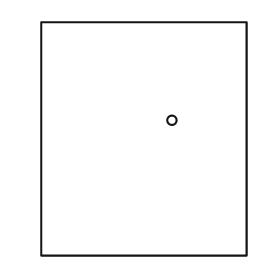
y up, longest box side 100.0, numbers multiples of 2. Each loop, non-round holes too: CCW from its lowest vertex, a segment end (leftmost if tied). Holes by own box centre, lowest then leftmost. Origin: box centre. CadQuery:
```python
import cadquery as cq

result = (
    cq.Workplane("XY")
    .moveTo(-44.0, -50.0)
    .lineTo(44.0, -50.0)
    .lineTo(44.0, 50.0)
    .lineTo(-44.0, 50.0)
    .close()
    .moveTo(12.0, 8.0)
    .circle(2.0)
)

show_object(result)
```